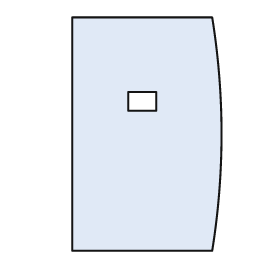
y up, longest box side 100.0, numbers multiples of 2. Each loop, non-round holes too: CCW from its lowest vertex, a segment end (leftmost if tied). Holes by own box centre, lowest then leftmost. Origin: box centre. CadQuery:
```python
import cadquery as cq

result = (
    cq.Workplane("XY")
    .moveTo(-32.0, -50.0)
    .lineTo(28.0, -50.0)
    .threePointArc((32.0, 0.0), (28.0, 50.0))
    .lineTo(-32.0, 50.0)
    .close()
    .moveTo(-8.0, 10.0)
    .lineTo(4.0, 10.0)
    .lineTo(4.0, 18.0)
    .lineTo(-8.0, 18.0)
    .close()
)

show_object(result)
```